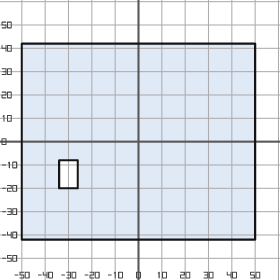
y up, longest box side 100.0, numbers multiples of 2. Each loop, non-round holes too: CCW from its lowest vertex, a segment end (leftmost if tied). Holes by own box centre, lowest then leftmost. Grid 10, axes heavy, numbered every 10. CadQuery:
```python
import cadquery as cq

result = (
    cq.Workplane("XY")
    .moveTo(-50.0, -42.0)
    .lineTo(50.0, -42.0)
    .lineTo(50.0, 42.0)
    .lineTo(-50.0, 42.0)
    .close()
    .moveTo(-34.0, -20.0)
    .lineTo(-26.0, -20.0)
    .lineTo(-26.0, -8.0)
    .lineTo(-34.0, -8.0)
    .close()
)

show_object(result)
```